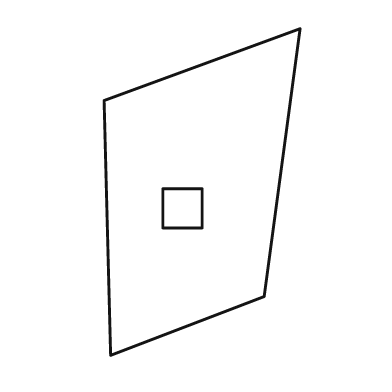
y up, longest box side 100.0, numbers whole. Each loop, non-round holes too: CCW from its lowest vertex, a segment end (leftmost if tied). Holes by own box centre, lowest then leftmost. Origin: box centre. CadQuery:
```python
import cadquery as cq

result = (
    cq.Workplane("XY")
    .moveTo(-28.0, -50.0)
    .lineTo(19.0, -32.0)
    .lineTo(30.0, 50.0)
    .lineTo(-30.0, 28.0)
    .close()
    .moveTo(-12.0, -11.0)
    .lineTo(0.0, -11.0)
    .lineTo(0.0, 1.0)
    .lineTo(-12.0, 1.0)
    .close()
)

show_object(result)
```